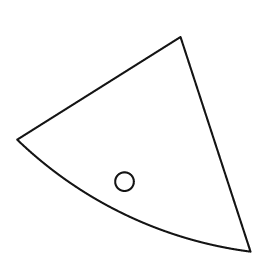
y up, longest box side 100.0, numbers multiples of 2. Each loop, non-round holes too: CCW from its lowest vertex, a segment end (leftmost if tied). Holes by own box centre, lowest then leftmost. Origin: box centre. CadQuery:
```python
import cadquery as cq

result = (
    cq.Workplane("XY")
    .moveTo(50.0, -46.0)
    .lineTo(20.0, 46.0)
    .lineTo(-50.0, 2.0)
    .threePointArc((-4.0, -30.0), (50.0, -46.0))
    .close()
    .moveTo(-4.0, -16.0)
    .circle(4.0)
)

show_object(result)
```